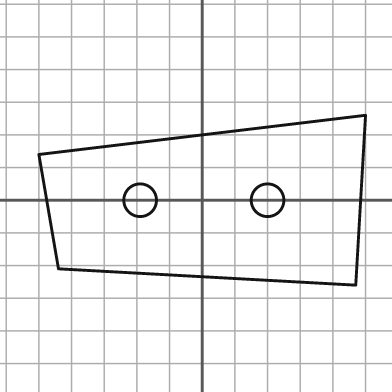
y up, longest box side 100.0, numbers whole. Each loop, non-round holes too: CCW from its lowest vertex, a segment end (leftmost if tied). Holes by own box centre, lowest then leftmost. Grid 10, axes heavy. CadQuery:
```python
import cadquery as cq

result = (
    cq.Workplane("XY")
    .moveTo(47.0, -26.0)
    .lineTo(50.0, 26.0)
    .lineTo(-50.0, 14.0)
    .lineTo(-44.0, -21.0)
    .close()
    .moveTo(-19.0, 0.0)
    .circle(5.0)
    .moveTo(20.0, 0.0)
    .circle(5.0)
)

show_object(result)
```